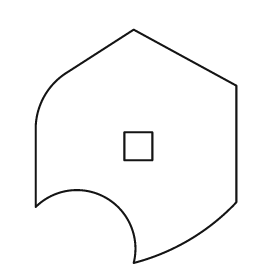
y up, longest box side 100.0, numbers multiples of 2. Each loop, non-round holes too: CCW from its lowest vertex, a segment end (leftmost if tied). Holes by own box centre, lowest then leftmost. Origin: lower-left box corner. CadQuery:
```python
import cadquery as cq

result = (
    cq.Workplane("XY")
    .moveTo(42.0, 0.0)
    .threePointArc((66.0, 10.0), (86.0, 26.0))
    .lineTo(86.0, 76.0)
    .lineTo(42.0, 100.0)
    .lineTo(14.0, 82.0)
    .threePointArc((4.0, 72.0), (0.0, 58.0))
    .lineTo(0.0, 24.0)
    .threePointArc((30.0, 28.0), (42.0, 0.0))
    .close()
    .moveTo(38.0, 44.0)
    .lineTo(50.0, 44.0)
    .lineTo(50.0, 56.0)
    .lineTo(38.0, 56.0)
    .close()
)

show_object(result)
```